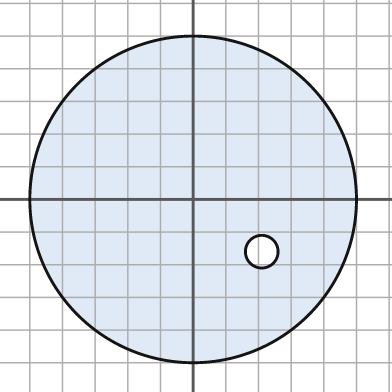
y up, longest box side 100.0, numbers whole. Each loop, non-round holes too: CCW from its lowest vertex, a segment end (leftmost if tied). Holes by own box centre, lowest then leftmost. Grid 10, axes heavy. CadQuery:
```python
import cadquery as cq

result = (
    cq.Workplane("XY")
    .moveTo(0.0, 0.0)
    .circle(50.0)
    .moveTo(21.0, -16.0)
    .circle(5.0)
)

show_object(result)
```